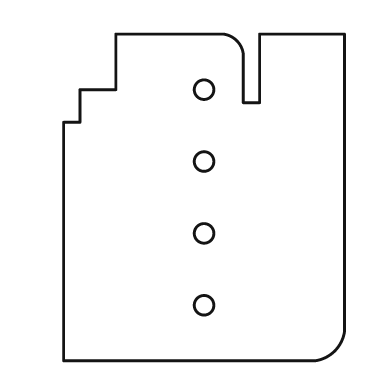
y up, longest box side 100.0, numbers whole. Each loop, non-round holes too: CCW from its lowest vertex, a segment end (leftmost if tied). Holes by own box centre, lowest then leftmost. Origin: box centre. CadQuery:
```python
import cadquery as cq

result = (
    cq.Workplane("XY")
    .moveTo(-43.0, -50.0)
    .lineTo(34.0, -50.0)
    .threePointArc((40.0, -47.0), (43.0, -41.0))
    .lineTo(43.0, 50.0)
    .lineTo(17.0, 50.0)
    .lineTo(17.0, 29.0)
    .lineTo(12.0, 29.0)
    .lineTo(12.0, 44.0)
    .threePointArc((10.0, 48.0), (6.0, 50.0))
    .lineTo(-27.0, 50.0)
    .lineTo(-27.0, 33.0)
    .lineTo(-38.0, 33.0)
    .lineTo(-38.0, 23.0)
    .lineTo(-43.0, 23.0)
    .close()
    .moveTo(0.0, -33.0)
    .circle(3.0)
    .moveTo(0.0, -11.0)
    .circle(3.0)
    .moveTo(0.0, 11.0)
    .circle(3.0)
    .moveTo(0.0, 33.0)
    .circle(3.0)
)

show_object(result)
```